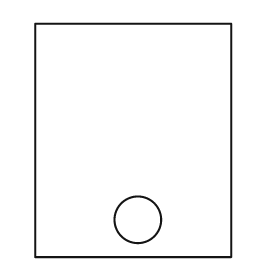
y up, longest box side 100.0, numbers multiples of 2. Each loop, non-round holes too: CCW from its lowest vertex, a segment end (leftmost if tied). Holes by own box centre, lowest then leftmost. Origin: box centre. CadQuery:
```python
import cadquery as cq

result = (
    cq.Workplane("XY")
    .moveTo(-42.0, -50.0)
    .lineTo(42.0, -50.0)
    .lineTo(42.0, 50.0)
    .lineTo(-42.0, 50.0)
    .close()
    .moveTo(2.0, -34.0)
    .circle(10.0)
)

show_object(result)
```